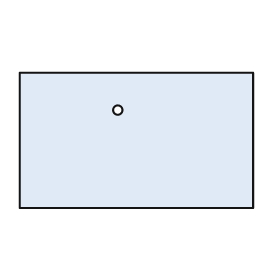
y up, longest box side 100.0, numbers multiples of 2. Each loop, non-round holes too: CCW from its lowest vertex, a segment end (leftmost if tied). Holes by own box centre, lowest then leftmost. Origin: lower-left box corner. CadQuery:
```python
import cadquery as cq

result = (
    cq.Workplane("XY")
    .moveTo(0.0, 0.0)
    .lineTo(100.0, 0.0)
    .lineTo(100.0, 58.0)
    .lineTo(0.0, 58.0)
    .close()
    .moveTo(42.0, 42.0)
    .circle(2.0)
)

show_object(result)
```